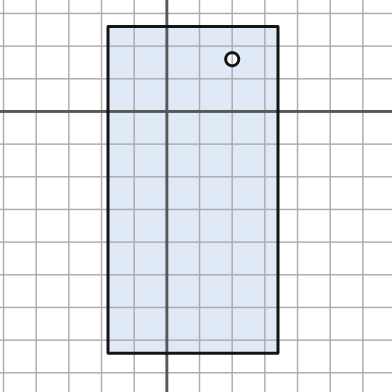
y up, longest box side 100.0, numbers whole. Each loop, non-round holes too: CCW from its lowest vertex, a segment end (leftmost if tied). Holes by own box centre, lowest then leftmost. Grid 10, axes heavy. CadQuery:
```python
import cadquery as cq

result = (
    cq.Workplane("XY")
    .moveTo(-18.0, -74.0)
    .lineTo(34.0, -74.0)
    .lineTo(34.0, 26.0)
    .lineTo(-18.0, 26.0)
    .close()
    .moveTo(20.0, 16.0)
    .circle(2.0)
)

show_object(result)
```